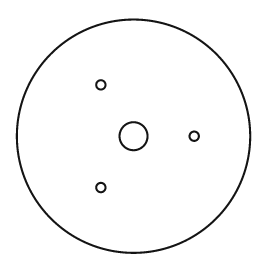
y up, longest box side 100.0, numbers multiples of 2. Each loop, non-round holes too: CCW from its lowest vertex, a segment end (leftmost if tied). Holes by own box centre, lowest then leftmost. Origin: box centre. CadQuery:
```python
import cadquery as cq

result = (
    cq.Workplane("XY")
    .moveTo(0.0, 0.0)
    .circle(50.0)
    .moveTo(-14.0, -22.0)
    .circle(2.0)
    .moveTo(0.0, 0.0)
    .circle(6.0)
    .moveTo(26.0, 0.0)
    .circle(2.0)
    .moveTo(-14.0, 22.0)
    .circle(2.0)
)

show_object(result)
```